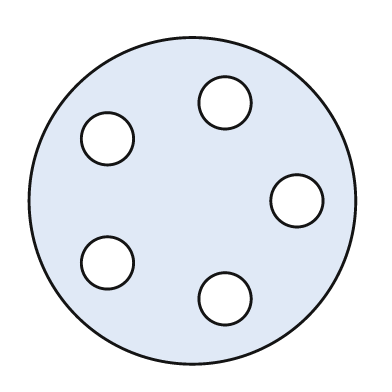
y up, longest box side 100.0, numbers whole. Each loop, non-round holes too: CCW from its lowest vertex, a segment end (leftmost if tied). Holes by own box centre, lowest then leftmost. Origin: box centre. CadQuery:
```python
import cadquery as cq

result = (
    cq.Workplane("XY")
    .moveTo(0.0, 0.0)
    .circle(50.0)
    .moveTo(10.0, -30.0)
    .circle(8.0)
    .moveTo(-26.0, -19.0)
    .circle(8.0)
    .moveTo(32.0, 0.0)
    .circle(8.0)
    .moveTo(-26.0, 19.0)
    .circle(8.0)
    .moveTo(10.0, 30.0)
    .circle(8.0)
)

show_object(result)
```